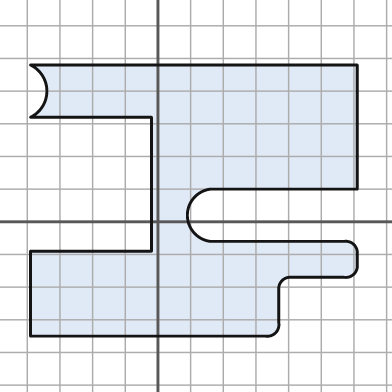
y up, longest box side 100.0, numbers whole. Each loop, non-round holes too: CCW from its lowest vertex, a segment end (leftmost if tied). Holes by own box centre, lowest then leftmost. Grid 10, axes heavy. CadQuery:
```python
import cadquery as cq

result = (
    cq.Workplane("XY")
    .moveTo(-39.0, -35.0)
    .lineTo(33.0, -35.0)
    .threePointArc((36.0, -34.0), (37.0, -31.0))
    .lineTo(37.0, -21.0)
    .threePointArc((38.0, -18.0), (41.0, -17.0))
    .lineTo(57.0, -17.0)
    .threePointArc((60.0, -16.0), (61.0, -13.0))
    .lineTo(61.0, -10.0)
    .threePointArc((60.0, -7.0), (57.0, -6.0))
    .lineTo(16.0, -6.0)
    .threePointArc((9.0, 2.0), (16.0, 10.0))
    .lineTo(61.0, 10.0)
    .lineTo(61.0, 48.0)
    .lineTo(-39.0, 48.0)
    .threePointArc((-34.0, 40.0), (-39.0, 32.0))
    .lineTo(-2.0, 32.0)
    .lineTo(-2.0, -9.0)
    .lineTo(-39.0, -9.0)
    .close()
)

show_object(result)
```